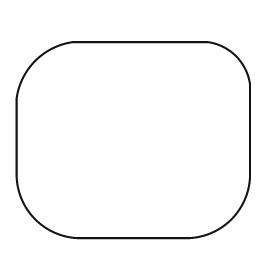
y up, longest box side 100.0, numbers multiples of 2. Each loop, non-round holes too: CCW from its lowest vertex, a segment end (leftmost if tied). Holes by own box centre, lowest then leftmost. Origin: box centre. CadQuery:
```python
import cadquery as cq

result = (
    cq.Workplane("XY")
    .moveTo(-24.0, -42.0)
    .lineTo(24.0, -42.0)
    .threePointArc((42.0, -34.0), (50.0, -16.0))
    .lineTo(50.0, 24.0)
    .threePointArc((44.0, 36.0), (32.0, 42.0))
    .lineTo(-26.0, 42.0)
    .threePointArc((-42.0, 34.0), (-50.0, 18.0))
    .lineTo(-50.0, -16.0)
    .threePointArc((-42.0, -34.0), (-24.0, -42.0))
    .close()
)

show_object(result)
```